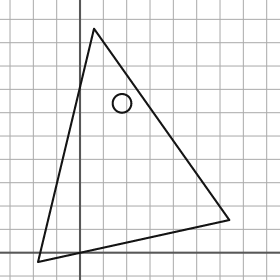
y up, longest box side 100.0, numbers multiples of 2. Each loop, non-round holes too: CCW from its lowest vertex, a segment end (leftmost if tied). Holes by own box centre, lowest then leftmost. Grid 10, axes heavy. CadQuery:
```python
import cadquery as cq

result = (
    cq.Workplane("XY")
    .moveTo(-18.0, -4.0)
    .lineTo(64.0, 14.0)
    .lineTo(6.0, 96.0)
    .close()
    .moveTo(18.0, 64.0)
    .circle(4.0)
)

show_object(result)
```